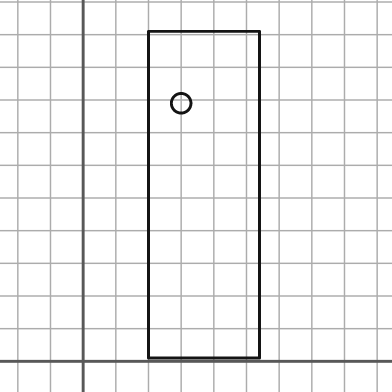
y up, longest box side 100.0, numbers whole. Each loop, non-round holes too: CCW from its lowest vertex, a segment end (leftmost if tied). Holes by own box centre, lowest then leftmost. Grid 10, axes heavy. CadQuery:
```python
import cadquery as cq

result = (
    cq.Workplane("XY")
    .moveTo(20.0, 1.0)
    .lineTo(54.0, 1.0)
    .lineTo(54.0, 101.0)
    .lineTo(20.0, 101.0)
    .close()
    .moveTo(30.0, 79.0)
    .circle(3.0)
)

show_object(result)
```